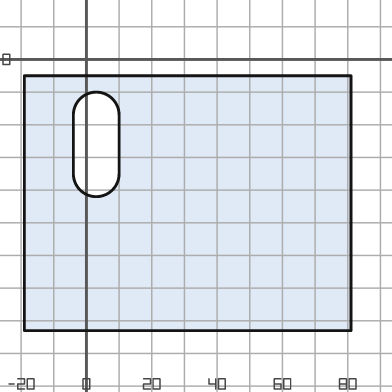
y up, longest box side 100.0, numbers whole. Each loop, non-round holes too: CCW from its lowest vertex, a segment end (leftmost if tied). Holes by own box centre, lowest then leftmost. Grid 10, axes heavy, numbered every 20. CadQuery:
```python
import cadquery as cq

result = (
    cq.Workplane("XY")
    .moveTo(-19.0, -83.0)
    .lineTo(81.0, -83.0)
    .lineTo(81.0, -5.0)
    .lineTo(-19.0, -5.0)
    .close()
    .moveTo(-4.0, -35.0)
    .threePointArc((3.0, -42.0), (10.0, -35.0))
    .lineTo(10.0, -17.0)
    .threePointArc((3.0, -10.0), (-4.0, -17.0))
    .close()
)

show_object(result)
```